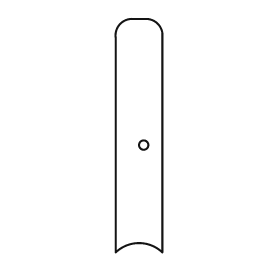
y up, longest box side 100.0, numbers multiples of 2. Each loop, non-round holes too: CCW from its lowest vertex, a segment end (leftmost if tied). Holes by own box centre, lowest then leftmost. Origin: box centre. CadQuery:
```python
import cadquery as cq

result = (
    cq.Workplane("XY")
    .moveTo(-10.0, -50.0)
    .threePointArc((0.0, -46.0), (10.0, -50.0))
    .lineTo(10.0, 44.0)
    .threePointArc((8.0, 48.0), (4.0, 50.0))
    .lineTo(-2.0, 50.0)
    .threePointArc((-8.0, 48.0), (-10.0, 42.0))
    .close()
    .moveTo(2.0, -4.0)
    .circle(2.0)
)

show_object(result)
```